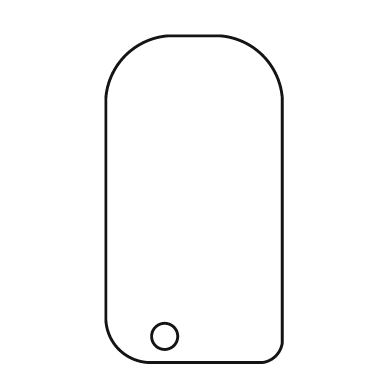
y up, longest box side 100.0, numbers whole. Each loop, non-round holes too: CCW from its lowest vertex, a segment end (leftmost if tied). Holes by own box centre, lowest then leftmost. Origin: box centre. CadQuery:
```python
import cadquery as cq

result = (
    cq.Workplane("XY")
    .moveTo(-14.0, -50.0)
    .lineTo(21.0, -50.0)
    .threePointArc((25.0, -48.0), (27.0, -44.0))
    .lineTo(27.0, 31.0)
    .threePointArc((21.0, 44.0), (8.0, 50.0))
    .lineTo(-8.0, 50.0)
    .threePointArc((-21.0, 44.0), (-27.0, 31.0))
    .lineTo(-27.0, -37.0)
    .threePointArc((-23.0, -46.0), (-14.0, -50.0))
    .close()
    .moveTo(-9.0, -42.0)
    .circle(4.0)
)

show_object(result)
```